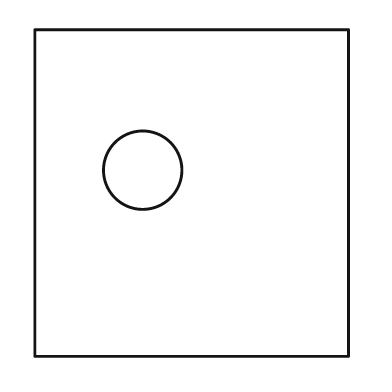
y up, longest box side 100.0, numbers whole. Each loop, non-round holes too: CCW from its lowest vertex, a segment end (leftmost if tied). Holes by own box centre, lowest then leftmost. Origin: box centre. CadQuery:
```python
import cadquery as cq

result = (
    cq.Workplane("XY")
    .moveTo(-48.0, -50.0)
    .lineTo(48.0, -50.0)
    .lineTo(48.0, 50.0)
    .lineTo(-48.0, 50.0)
    .close()
    .moveTo(-15.0, 7.0)
    .circle(12.0)
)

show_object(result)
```